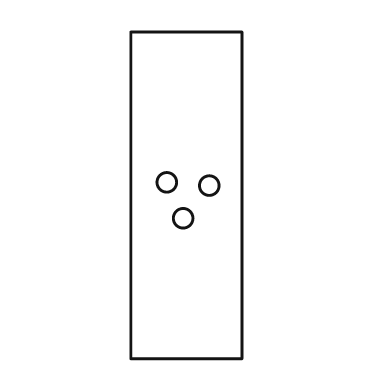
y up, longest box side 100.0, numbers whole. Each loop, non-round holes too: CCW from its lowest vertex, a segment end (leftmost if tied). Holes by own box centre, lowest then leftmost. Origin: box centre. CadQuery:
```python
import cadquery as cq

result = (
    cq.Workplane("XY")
    .moveTo(-17.0, -50.0)
    .lineTo(17.0, -50.0)
    .lineTo(17.0, 50.0)
    .lineTo(-17.0, 50.0)
    .close()
    .moveTo(-1.0, -7.0)
    .circle(3.0)
    .moveTo(7.0, 3.0)
    .circle(3.0)
    .moveTo(-6.0, 4.0)
    .circle(3.0)
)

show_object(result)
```